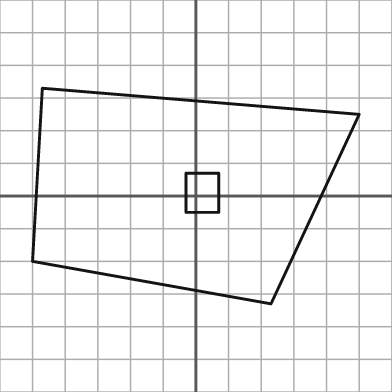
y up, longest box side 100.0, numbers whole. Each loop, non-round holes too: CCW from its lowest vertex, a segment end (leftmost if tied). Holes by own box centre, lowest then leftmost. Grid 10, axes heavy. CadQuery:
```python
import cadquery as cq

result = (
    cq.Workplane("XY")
    .moveTo(23.0, -33.0)
    .lineTo(50.0, 25.0)
    .lineTo(-47.0, 33.0)
    .lineTo(-50.0, -20.0)
    .close()
    .moveTo(-3.0, -5.0)
    .lineTo(7.0, -5.0)
    .lineTo(7.0, 7.0)
    .lineTo(-3.0, 7.0)
    .close()
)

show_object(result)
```